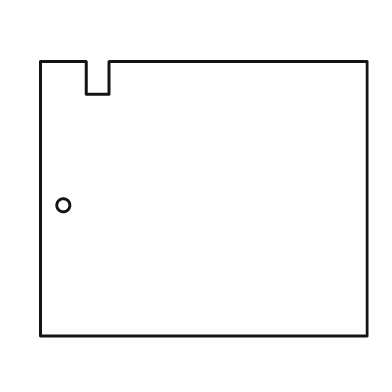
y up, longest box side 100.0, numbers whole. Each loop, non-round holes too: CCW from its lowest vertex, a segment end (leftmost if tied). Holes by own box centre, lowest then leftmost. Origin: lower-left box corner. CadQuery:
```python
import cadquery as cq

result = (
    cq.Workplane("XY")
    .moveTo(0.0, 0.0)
    .lineTo(100.0, 0.0)
    .lineTo(100.0, 84.0)
    .lineTo(21.0, 84.0)
    .lineTo(21.0, 74.0)
    .lineTo(14.0, 74.0)
    .lineTo(14.0, 84.0)
    .lineTo(0.0, 84.0)
    .close()
    .moveTo(7.0, 40.0)
    .circle(2.0)
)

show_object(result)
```